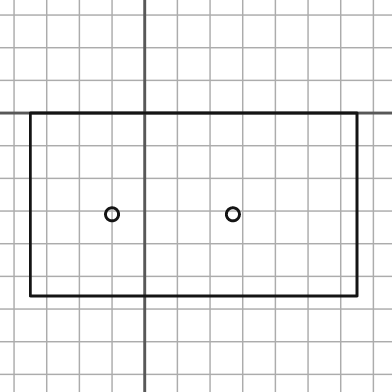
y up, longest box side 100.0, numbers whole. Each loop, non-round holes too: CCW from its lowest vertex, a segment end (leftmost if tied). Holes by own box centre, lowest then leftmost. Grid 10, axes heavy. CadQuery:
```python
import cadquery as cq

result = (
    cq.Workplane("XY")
    .moveTo(-35.0, -56.0)
    .lineTo(65.0, -56.0)
    .lineTo(65.0, 0.0)
    .lineTo(-35.0, 0.0)
    .close()
    .moveTo(-10.0, -31.0)
    .circle(2.0)
    .moveTo(27.0, -31.0)
    .circle(2.0)
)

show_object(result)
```